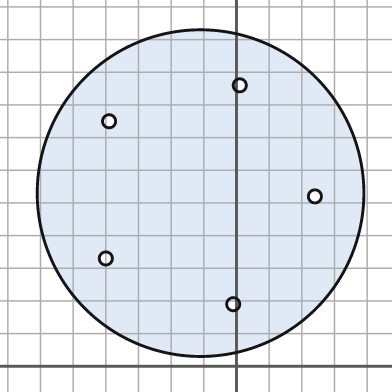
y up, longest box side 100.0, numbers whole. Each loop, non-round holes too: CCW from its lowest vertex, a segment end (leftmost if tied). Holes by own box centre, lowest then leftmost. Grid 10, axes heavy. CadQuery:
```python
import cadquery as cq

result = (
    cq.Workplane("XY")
    .moveTo(-11.0, 53.0)
    .circle(50.0)
    .moveTo(-1.0, 19.0)
    .circle(2.0)
    .moveTo(-40.0, 33.0)
    .circle(2.0)
    .moveTo(24.0, 52.0)
    .circle(2.0)
    .moveTo(-39.0, 75.0)
    .circle(2.0)
    .moveTo(1.0, 86.0)
    .circle(2.0)
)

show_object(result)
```